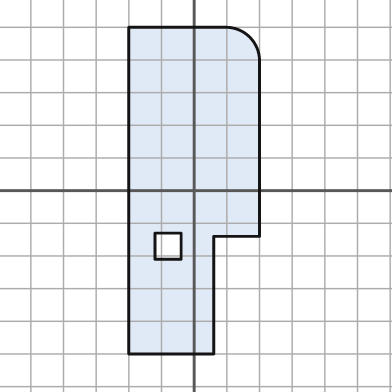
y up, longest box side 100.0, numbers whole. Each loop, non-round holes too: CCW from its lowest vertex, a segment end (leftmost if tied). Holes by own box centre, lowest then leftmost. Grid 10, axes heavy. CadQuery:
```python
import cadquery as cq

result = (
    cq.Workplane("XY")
    .moveTo(-20.0, -50.0)
    .lineTo(6.0, -50.0)
    .lineTo(6.0, -14.0)
    .lineTo(20.0, -14.0)
    .lineTo(20.0, 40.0)
    .threePointArc((17.0, 47.0), (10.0, 50.0))
    .lineTo(-20.0, 50.0)
    .close()
    .moveTo(-12.0, -21.0)
    .lineTo(-4.0, -21.0)
    .lineTo(-4.0, -13.0)
    .lineTo(-12.0, -13.0)
    .close()
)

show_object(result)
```